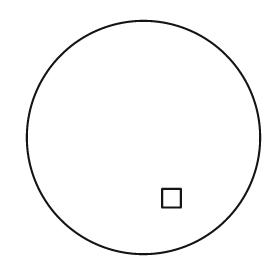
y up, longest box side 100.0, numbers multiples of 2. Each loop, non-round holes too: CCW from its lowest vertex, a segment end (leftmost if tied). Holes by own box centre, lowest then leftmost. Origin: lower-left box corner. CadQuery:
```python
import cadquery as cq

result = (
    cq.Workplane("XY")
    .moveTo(50.0, 50.0)
    .circle(50.0)
    .moveTo(58.0, 20.0)
    .lineTo(66.0, 20.0)
    .lineTo(66.0, 28.0)
    .lineTo(58.0, 28.0)
    .close()
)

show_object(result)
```